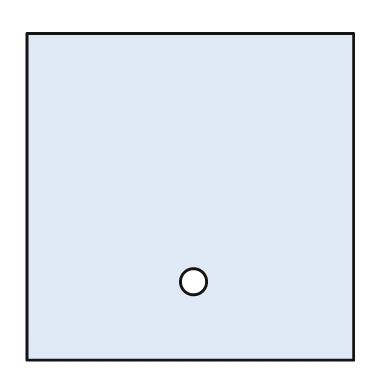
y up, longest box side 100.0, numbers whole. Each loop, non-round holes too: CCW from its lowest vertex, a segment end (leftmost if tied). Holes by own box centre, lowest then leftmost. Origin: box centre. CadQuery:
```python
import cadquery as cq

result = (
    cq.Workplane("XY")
    .moveTo(-50.0, -50.0)
    .lineTo(50.0, -50.0)
    .lineTo(50.0, 50.0)
    .lineTo(-50.0, 50.0)
    .close()
    .moveTo(1.0, -26.0)
    .circle(4.0)
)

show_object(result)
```